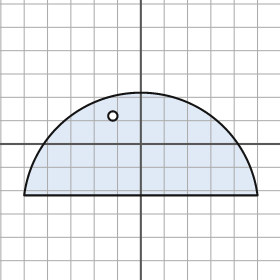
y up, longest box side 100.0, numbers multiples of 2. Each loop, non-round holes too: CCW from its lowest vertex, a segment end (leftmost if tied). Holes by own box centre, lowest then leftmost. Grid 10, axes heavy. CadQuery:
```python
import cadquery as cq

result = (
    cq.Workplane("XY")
    .moveTo(-50.0, -22.0)
    .lineTo(50.0, -22.0)
    .threePointArc((0.0, 22.0), (-50.0, -22.0))
    .close()
    .moveTo(-12.0, 12.0)
    .circle(2.0)
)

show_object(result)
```